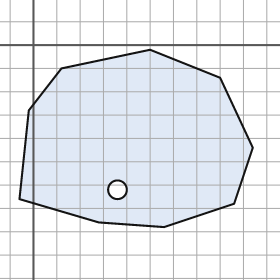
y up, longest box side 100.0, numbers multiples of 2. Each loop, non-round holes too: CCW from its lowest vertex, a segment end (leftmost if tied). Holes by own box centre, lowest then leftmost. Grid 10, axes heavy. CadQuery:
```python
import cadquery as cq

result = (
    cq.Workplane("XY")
    .moveTo(56.0, -78.0)
    .lineTo(86.0, -68.0)
    .lineTo(94.0, -44.0)
    .lineTo(80.0, -14.0)
    .lineTo(50.0, -2.0)
    .lineTo(12.0, -10.0)
    .lineTo(-2.0, -28.0)
    .lineTo(-6.0, -66.0)
    .lineTo(28.0, -76.0)
    .close()
    .moveTo(36.0, -62.0)
    .circle(4.0)
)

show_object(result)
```